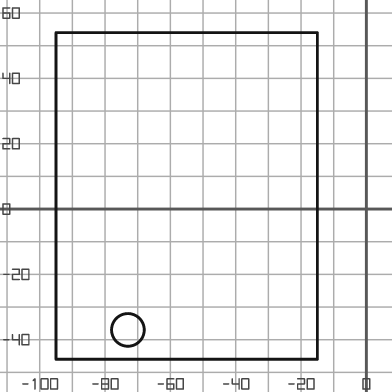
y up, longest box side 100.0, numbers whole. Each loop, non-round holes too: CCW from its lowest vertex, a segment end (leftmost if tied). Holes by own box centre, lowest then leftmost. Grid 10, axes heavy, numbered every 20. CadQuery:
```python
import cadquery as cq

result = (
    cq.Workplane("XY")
    .moveTo(-95.0, -46.0)
    .lineTo(-15.0, -46.0)
    .lineTo(-15.0, 54.0)
    .lineTo(-95.0, 54.0)
    .close()
    .moveTo(-73.0, -37.0)
    .circle(5.0)
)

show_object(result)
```